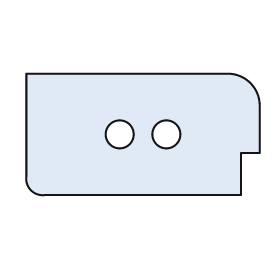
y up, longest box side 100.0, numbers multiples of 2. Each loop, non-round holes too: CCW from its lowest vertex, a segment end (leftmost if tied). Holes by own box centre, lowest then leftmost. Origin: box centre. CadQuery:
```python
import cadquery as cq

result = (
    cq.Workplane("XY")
    .moveTo(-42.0, -26.0)
    .lineTo(42.0, -26.0)
    .lineTo(42.0, -8.0)
    .lineTo(50.0, -8.0)
    .lineTo(50.0, 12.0)
    .threePointArc((46.0, 22.0), (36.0, 26.0))
    .lineTo(-50.0, 26.0)
    .lineTo(-50.0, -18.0)
    .threePointArc((-48.0, -24.0), (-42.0, -26.0))
    .close()
    .moveTo(-10.0, 0.0)
    .circle(6.0)
    .moveTo(10.0, 0.0)
    .circle(6.0)
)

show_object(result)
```